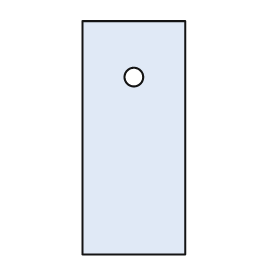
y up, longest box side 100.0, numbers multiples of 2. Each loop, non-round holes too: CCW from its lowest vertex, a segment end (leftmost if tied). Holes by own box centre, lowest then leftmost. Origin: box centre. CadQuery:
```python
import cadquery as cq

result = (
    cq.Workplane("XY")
    .moveTo(-22.0, -50.0)
    .lineTo(22.0, -50.0)
    .lineTo(22.0, 50.0)
    .lineTo(-22.0, 50.0)
    .close()
    .moveTo(0.0, 26.0)
    .circle(4.0)
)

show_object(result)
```